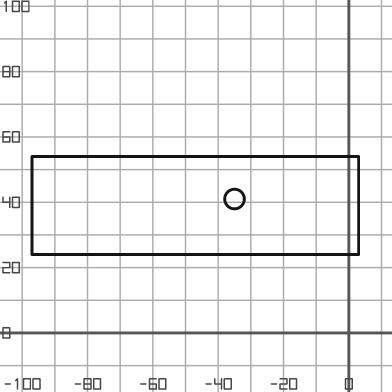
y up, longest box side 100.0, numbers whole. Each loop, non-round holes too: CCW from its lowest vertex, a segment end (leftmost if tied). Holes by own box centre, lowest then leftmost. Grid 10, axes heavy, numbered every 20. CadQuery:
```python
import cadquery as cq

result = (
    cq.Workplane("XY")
    .moveTo(-97.0, 24.0)
    .lineTo(3.0, 24.0)
    .lineTo(3.0, 54.0)
    .lineTo(-97.0, 54.0)
    .close()
    .moveTo(-35.0, 41.0)
    .circle(3.0)
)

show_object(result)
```